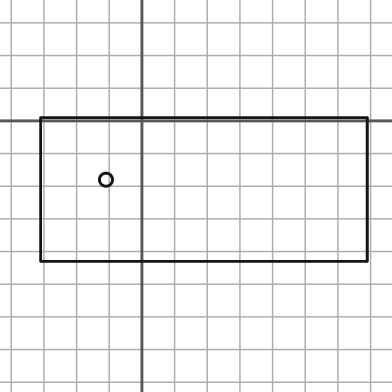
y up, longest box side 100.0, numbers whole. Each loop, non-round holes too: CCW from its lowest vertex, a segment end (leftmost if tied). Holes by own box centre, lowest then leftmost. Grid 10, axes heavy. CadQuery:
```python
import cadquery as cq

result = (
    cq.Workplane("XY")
    .moveTo(-31.0, -43.0)
    .lineTo(69.0, -43.0)
    .lineTo(69.0, 1.0)
    .lineTo(-31.0, 1.0)
    .close()
    .moveTo(-11.0, -18.0)
    .circle(2.0)
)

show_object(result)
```